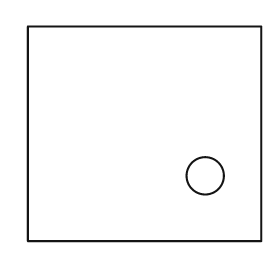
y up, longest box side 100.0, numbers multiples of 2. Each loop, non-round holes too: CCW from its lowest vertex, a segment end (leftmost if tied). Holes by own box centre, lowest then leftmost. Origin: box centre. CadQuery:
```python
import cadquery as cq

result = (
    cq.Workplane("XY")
    .moveTo(-50.0, -46.0)
    .lineTo(50.0, -46.0)
    .lineTo(50.0, 46.0)
    .lineTo(-50.0, 46.0)
    .close()
    .moveTo(26.0, -18.0)
    .circle(8.0)
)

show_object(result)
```